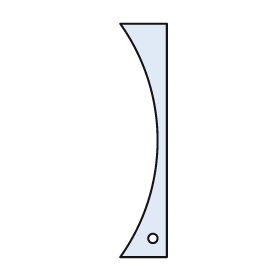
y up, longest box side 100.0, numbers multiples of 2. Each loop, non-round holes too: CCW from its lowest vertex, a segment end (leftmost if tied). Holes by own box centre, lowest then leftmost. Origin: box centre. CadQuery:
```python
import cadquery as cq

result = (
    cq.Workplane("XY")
    .moveTo(-10.0, -50.0)
    .lineTo(10.0, -50.0)
    .lineTo(10.0, 50.0)
    .lineTo(-10.0, 50.0)
    .threePointArc((6.0, 0.0), (-10.0, -50.0))
    .close()
    .moveTo(4.0, -42.0)
    .circle(2.0)
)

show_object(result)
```